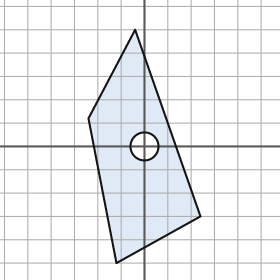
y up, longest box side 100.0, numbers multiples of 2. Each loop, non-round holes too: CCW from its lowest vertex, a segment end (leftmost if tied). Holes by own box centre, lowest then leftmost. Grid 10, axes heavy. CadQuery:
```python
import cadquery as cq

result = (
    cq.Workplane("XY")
    .moveTo(-12.0, -50.0)
    .lineTo(24.0, -30.0)
    .lineTo(-4.0, 50.0)
    .lineTo(-24.0, 12.0)
    .close()
    .moveTo(0.0, 0.0)
    .circle(6.0)
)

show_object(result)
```